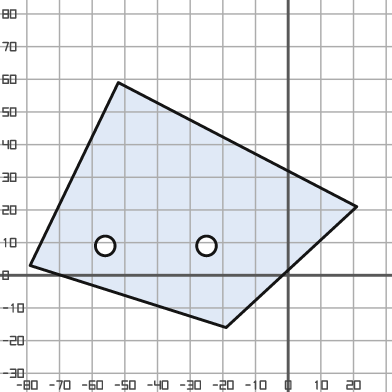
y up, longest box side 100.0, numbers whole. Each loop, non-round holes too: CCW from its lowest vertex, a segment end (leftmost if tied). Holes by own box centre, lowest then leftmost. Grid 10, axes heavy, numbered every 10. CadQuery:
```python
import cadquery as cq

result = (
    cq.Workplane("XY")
    .moveTo(-19.0, -16.0)
    .lineTo(21.0, 21.0)
    .lineTo(-52.0, 59.0)
    .lineTo(-79.0, 3.0)
    .close()
    .moveTo(-56.0, 9.0)
    .circle(3.0)
    .moveTo(-25.0, 9.0)
    .circle(3.0)
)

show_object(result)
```